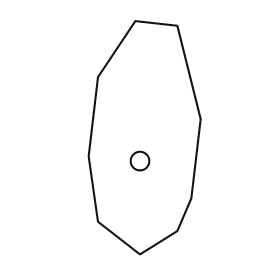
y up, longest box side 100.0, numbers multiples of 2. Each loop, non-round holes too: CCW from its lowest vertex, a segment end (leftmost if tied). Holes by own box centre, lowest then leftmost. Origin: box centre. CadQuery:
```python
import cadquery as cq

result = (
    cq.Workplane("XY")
    .moveTo(-2.0, -50.0)
    .lineTo(14.0, -40.0)
    .lineTo(20.0, -26.0)
    .lineTo(24.0, 8.0)
    .lineTo(14.0, 48.0)
    .lineTo(-4.0, 50.0)
    .lineTo(-20.0, 26.0)
    .lineTo(-24.0, -8.0)
    .lineTo(-20.0, -36.0)
    .close()
    .moveTo(-2.0, -10.0)
    .circle(4.0)
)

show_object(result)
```